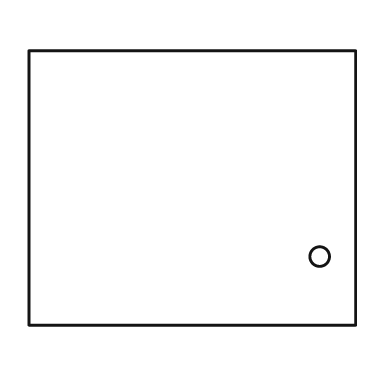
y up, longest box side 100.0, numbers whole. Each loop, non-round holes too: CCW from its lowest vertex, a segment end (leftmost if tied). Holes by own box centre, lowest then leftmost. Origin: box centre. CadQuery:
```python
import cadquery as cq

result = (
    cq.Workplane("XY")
    .moveTo(-50.0, -42.0)
    .lineTo(50.0, -42.0)
    .lineTo(50.0, 42.0)
    .lineTo(-50.0, 42.0)
    .close()
    .moveTo(39.0, -21.0)
    .circle(3.0)
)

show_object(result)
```